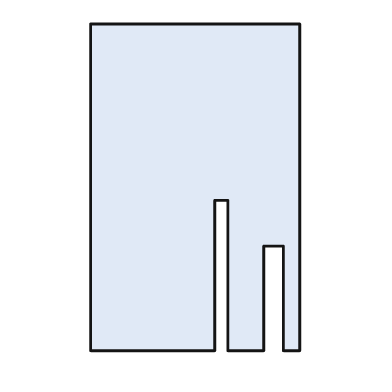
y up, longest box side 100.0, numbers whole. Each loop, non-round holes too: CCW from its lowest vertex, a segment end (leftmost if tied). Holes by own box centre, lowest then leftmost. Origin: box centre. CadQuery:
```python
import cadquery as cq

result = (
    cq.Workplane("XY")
    .moveTo(-32.0, -50.0)
    .lineTo(6.0, -50.0)
    .lineTo(6.0, -4.0)
    .lineTo(10.0, -4.0)
    .lineTo(10.0, -50.0)
    .lineTo(21.0, -50.0)
    .lineTo(21.0, -18.0)
    .lineTo(27.0, -18.0)
    .lineTo(27.0, -50.0)
    .lineTo(32.0, -50.0)
    .lineTo(32.0, 50.0)
    .lineTo(-32.0, 50.0)
    .close()
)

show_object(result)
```